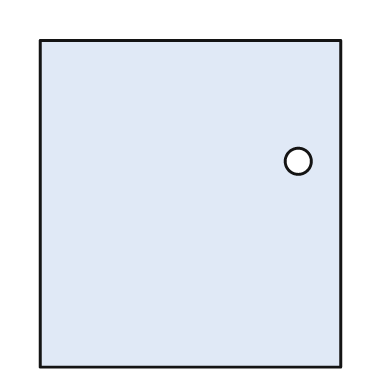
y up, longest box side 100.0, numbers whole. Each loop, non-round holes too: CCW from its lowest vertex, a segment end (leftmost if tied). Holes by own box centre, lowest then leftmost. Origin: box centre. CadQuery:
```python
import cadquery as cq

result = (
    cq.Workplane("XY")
    .moveTo(-46.0, -50.0)
    .lineTo(46.0, -50.0)
    .lineTo(46.0, 50.0)
    .lineTo(-46.0, 50.0)
    .close()
    .moveTo(33.0, 13.0)
    .circle(4.0)
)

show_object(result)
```